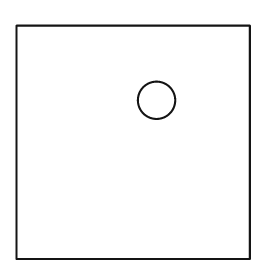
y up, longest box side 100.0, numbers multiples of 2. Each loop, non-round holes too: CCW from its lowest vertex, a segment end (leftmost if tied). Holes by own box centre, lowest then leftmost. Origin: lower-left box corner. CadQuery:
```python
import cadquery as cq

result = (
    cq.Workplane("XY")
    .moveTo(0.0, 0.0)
    .lineTo(100.0, 0.0)
    .lineTo(100.0, 100.0)
    .lineTo(0.0, 100.0)
    .close()
    .moveTo(60.0, 68.0)
    .circle(8.0)
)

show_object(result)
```